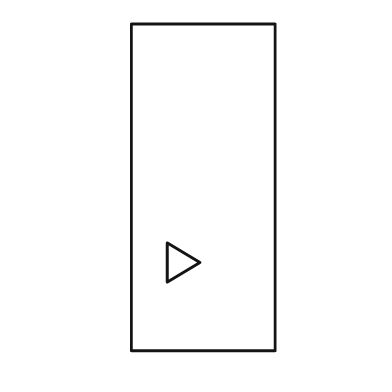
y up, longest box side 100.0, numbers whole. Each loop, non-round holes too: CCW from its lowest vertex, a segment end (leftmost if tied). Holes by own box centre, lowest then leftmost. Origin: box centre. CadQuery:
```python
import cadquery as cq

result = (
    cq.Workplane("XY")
    .moveTo(-22.0, -50.0)
    .lineTo(22.0, -50.0)
    .lineTo(22.0, 50.0)
    .lineTo(-22.0, 50.0)
    .close()
    .moveTo(-11.0, -29.0)
    .lineTo(-1.0, -23.0)
    .lineTo(-11.0, -17.0)
    .close()
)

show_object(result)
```